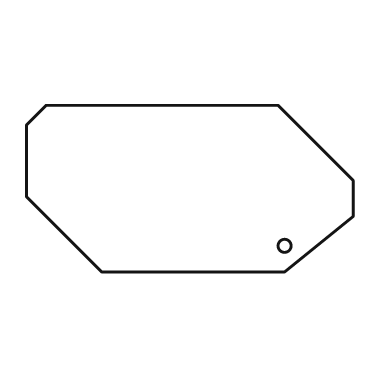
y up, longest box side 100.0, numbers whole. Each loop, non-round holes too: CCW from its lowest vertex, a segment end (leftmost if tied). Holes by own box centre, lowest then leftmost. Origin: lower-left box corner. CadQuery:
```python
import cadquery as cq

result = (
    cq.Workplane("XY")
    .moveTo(23.0, 0.0)
    .lineTo(79.0, 0.0)
    .lineTo(100.0, 17.0)
    .lineTo(100.0, 28.0)
    .lineTo(77.0, 51.0)
    .lineTo(6.0, 51.0)
    .lineTo(0.0, 45.0)
    .lineTo(0.0, 23.0)
    .close()
    .moveTo(79.0, 8.0)
    .circle(2.0)
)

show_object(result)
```